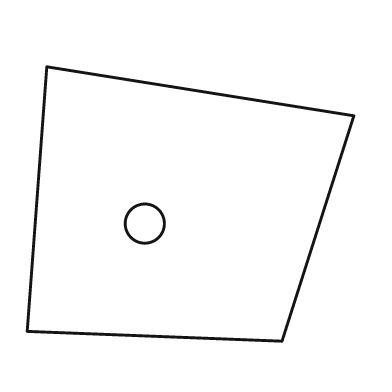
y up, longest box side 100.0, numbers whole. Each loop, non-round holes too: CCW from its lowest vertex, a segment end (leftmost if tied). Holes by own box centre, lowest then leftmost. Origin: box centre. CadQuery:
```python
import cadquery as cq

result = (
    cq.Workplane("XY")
    .moveTo(28.0, -42.0)
    .lineTo(50.0, 27.0)
    .lineTo(-44.0, 42.0)
    .lineTo(-50.0, -39.0)
    .close()
    .moveTo(-14.0, -6.0)
    .circle(6.0)
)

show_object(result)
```